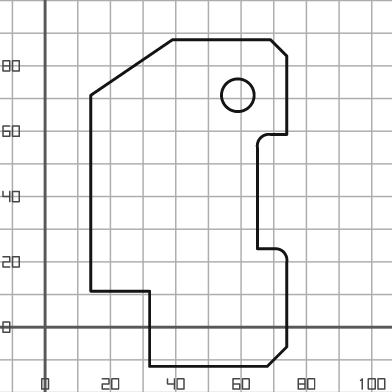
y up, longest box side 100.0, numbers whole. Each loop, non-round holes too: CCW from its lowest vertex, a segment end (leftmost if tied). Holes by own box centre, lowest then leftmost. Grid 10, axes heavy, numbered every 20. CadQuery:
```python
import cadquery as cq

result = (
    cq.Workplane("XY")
    .moveTo(32.0, -12.0)
    .lineTo(68.0, -12.0)
    .lineTo(74.0, -6.0)
    .lineTo(74.0, 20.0)
    .threePointArc((73.0, 23.0), (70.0, 24.0))
    .lineTo(65.0, 24.0)
    .lineTo(65.0, 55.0)
    .threePointArc((66.0, 58.0), (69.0, 59.0))
    .lineTo(74.0, 59.0)
    .lineTo(74.0, 83.0)
    .lineTo(69.0, 88.0)
    .lineTo(39.0, 88.0)
    .lineTo(14.0, 71.0)
    .lineTo(14.0, 11.0)
    .lineTo(32.0, 11.0)
    .close()
    .moveTo(59.0, 71.0)
    .circle(5.0)
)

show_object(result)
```